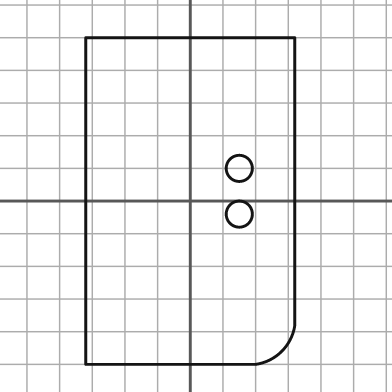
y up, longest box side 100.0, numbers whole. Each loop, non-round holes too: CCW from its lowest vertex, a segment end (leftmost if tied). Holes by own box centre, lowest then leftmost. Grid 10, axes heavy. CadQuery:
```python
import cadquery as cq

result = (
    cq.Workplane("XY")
    .moveTo(-32.0, -50.0)
    .lineTo(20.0, -50.0)
    .threePointArc((28.0, -46.0), (32.0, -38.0))
    .lineTo(32.0, 50.0)
    .lineTo(-32.0, 50.0)
    .close()
    .moveTo(15.0, -4.0)
    .circle(4.0)
    .moveTo(15.0, 10.0)
    .circle(4.0)
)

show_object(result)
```